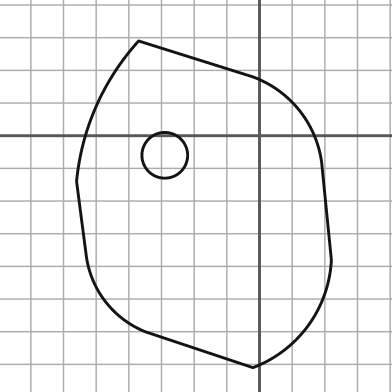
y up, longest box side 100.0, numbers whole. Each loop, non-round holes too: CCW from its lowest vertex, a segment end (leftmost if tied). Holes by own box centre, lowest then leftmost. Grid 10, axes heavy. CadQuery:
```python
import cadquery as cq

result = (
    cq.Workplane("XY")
    .moveTo(-2.0, -71.0)
    .threePointArc((15.0, -58.0), (22.0, -38.0))
    .lineTo(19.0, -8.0)
    .threePointArc((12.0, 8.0), (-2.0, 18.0))
    .lineTo(-37.0, 29.0)
    .threePointArc((-50.0, 9.0), (-56.0, -14.0))
    .lineTo(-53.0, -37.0)
    .threePointArc((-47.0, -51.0), (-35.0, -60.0))
    .close()
    .moveTo(-29.0, -6.0)
    .circle(7.0)
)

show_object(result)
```